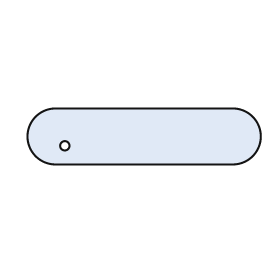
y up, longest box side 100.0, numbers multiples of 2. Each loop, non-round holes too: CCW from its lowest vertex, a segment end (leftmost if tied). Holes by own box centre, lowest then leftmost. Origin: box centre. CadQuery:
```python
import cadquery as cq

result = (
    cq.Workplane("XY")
    .moveTo(-38.0, -12.0)
    .lineTo(38.0, -12.0)
    .threePointArc((50.0, 0.0), (38.0, 12.0))
    .lineTo(-38.0, 12.0)
    .threePointArc((-50.0, 0.0), (-38.0, -12.0))
    .close()
    .moveTo(-34.0, -4.0)
    .circle(2.0)
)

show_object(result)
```